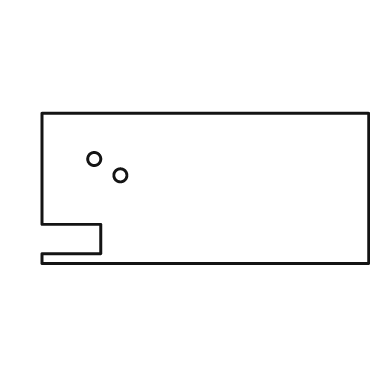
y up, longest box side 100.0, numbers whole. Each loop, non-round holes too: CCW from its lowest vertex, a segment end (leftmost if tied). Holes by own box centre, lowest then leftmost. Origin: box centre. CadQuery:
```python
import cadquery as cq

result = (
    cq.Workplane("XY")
    .moveTo(-50.0, -23.0)
    .lineTo(50.0, -23.0)
    .lineTo(50.0, 23.0)
    .lineTo(-50.0, 23.0)
    .lineTo(-50.0, -11.0)
    .lineTo(-32.0, -11.0)
    .lineTo(-32.0, -20.0)
    .lineTo(-50.0, -20.0)
    .close()
    .moveTo(-26.0, 4.0)
    .circle(2.0)
    .moveTo(-34.0, 9.0)
    .circle(2.0)
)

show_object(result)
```